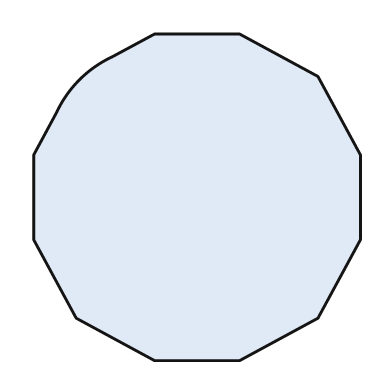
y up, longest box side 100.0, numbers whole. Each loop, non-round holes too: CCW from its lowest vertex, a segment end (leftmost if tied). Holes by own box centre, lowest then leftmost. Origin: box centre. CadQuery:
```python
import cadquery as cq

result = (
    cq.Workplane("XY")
    .moveTo(-13.0, -50.0)
    .lineTo(13.0, -50.0)
    .lineTo(37.0, -37.0)
    .lineTo(50.0, -13.0)
    .lineTo(50.0, 13.0)
    .lineTo(37.0, 37.0)
    .lineTo(13.0, 50.0)
    .lineTo(-13.0, 50.0)
    .lineTo(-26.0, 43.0)
    .threePointArc((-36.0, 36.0), (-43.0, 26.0))
    .lineTo(-50.0, 13.0)
    .lineTo(-50.0, -13.0)
    .lineTo(-37.0, -37.0)
    .close()
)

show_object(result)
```